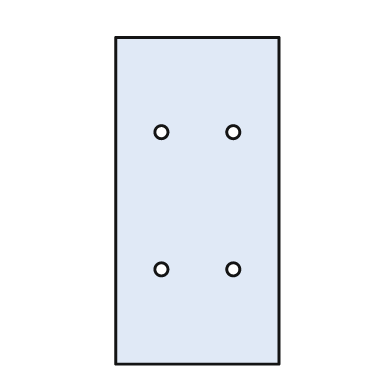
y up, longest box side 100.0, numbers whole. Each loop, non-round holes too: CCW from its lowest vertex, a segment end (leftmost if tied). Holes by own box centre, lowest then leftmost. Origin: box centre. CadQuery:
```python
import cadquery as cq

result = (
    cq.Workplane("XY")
    .moveTo(-25.0, -50.0)
    .lineTo(25.0, -50.0)
    .lineTo(25.0, 50.0)
    .lineTo(-25.0, 50.0)
    .close()
    .moveTo(-11.0, -21.0)
    .circle(2.0)
    .moveTo(11.0, -21.0)
    .circle(2.0)
    .moveTo(-11.0, 21.0)
    .circle(2.0)
    .moveTo(11.0, 21.0)
    .circle(2.0)
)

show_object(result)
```